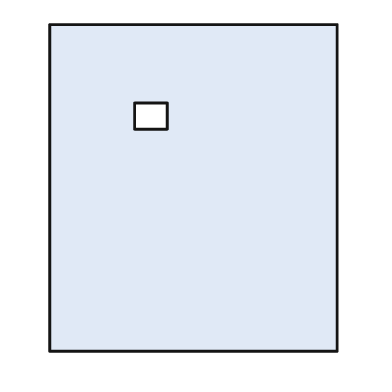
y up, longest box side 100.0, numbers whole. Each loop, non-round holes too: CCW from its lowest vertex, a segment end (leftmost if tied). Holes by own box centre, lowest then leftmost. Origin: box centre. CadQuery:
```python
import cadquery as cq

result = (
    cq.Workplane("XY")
    .moveTo(-44.0, -50.0)
    .lineTo(44.0, -50.0)
    .lineTo(44.0, 50.0)
    .lineTo(-44.0, 50.0)
    .close()
    .moveTo(-18.0, 18.0)
    .lineTo(-8.0, 18.0)
    .lineTo(-8.0, 26.0)
    .lineTo(-18.0, 26.0)
    .close()
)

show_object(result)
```